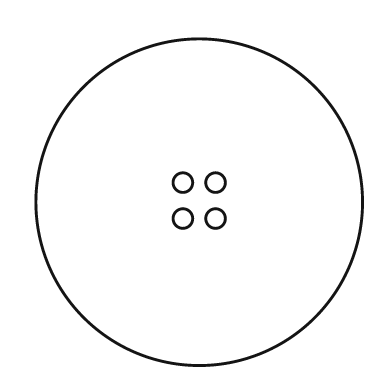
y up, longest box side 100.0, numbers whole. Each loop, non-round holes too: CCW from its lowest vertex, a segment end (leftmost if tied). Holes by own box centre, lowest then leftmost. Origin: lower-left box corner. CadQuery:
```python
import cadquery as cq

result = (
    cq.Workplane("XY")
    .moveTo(50.0, 50.0)
    .circle(50.0)
    .moveTo(45.0, 45.0)
    .circle(3.0)
    .moveTo(55.0, 45.0)
    .circle(3.0)
    .moveTo(45.0, 56.0)
    .circle(3.0)
    .moveTo(55.0, 56.0)
    .circle(3.0)
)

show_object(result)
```